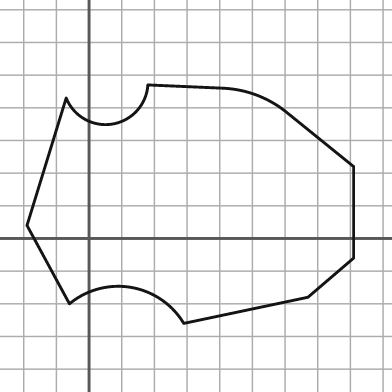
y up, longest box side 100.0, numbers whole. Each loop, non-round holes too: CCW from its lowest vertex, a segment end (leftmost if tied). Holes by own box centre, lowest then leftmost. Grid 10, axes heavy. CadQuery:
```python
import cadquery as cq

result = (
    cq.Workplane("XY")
    .moveTo(29.0, -26.0)
    .lineTo(67.0, -18.0)
    .lineTo(81.0, -6.0)
    .lineTo(81.0, 22.0)
    .lineTo(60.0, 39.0)
    .threePointArc((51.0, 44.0), (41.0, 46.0))
    .lineTo(18.0, 47.0)
    .threePointArc((7.0, 35.0), (-7.0, 43.0))
    .lineTo(-19.0, 4.0)
    .lineTo(-6.0, -20.0)
    .threePointArc((13.0, -15.0), (29.0, -26.0))
    .close()
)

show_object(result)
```